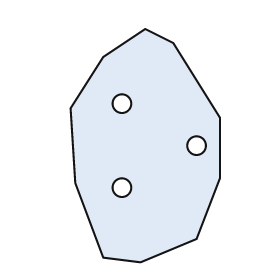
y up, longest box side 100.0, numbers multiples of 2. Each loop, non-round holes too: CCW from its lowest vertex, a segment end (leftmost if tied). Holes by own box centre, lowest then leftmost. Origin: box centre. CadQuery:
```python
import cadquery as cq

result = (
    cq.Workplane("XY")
    .moveTo(-2.0, -50.0)
    .lineTo(22.0, -40.0)
    .lineTo(32.0, -14.0)
    .lineTo(32.0, 12.0)
    .lineTo(12.0, 44.0)
    .lineTo(0.0, 50.0)
    .lineTo(-18.0, 38.0)
    .lineTo(-32.0, 16.0)
    .lineTo(-30.0, -16.0)
    .lineTo(-18.0, -48.0)
    .close()
    .moveTo(-10.0, -18.0)
    .circle(4.0)
    .moveTo(22.0, 0.0)
    .circle(4.0)
    .moveTo(-10.0, 18.0)
    .circle(4.0)
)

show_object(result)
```